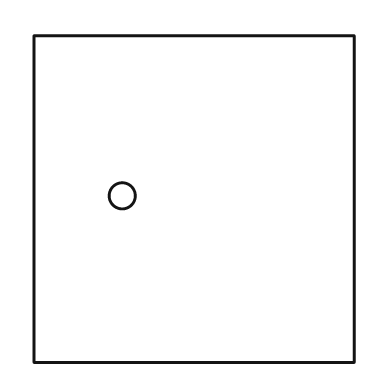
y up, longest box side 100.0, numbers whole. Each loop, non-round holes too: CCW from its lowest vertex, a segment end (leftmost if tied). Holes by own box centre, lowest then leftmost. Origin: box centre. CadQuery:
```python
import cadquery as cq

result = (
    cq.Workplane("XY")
    .moveTo(-49.0, -50.0)
    .lineTo(49.0, -50.0)
    .lineTo(49.0, 50.0)
    .lineTo(-49.0, 50.0)
    .close()
    .moveTo(-22.0, 1.0)
    .circle(4.0)
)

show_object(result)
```